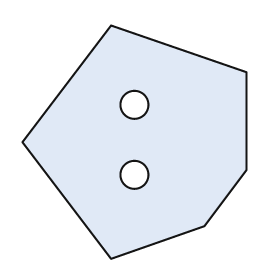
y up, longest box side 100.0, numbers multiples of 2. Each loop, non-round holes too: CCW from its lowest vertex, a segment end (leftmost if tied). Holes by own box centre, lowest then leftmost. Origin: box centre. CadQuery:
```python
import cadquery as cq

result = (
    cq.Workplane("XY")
    .moveTo(-10.0, -50.0)
    .lineTo(30.0, -36.0)
    .lineTo(48.0, -12.0)
    .lineTo(48.0, 30.0)
    .lineTo(-10.0, 50.0)
    .lineTo(-48.0, 0.0)
    .close()
    .moveTo(0.0, -14.0)
    .circle(6.0)
    .moveTo(0.0, 16.0)
    .circle(6.0)
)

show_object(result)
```